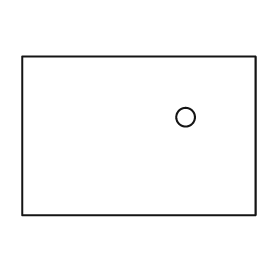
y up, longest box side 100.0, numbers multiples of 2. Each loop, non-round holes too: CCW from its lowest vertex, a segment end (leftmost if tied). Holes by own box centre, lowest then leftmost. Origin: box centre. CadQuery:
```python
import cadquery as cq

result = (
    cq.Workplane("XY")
    .moveTo(-50.0, -34.0)
    .lineTo(50.0, -34.0)
    .lineTo(50.0, 34.0)
    .lineTo(-50.0, 34.0)
    .close()
    .moveTo(20.0, 8.0)
    .circle(4.0)
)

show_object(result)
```